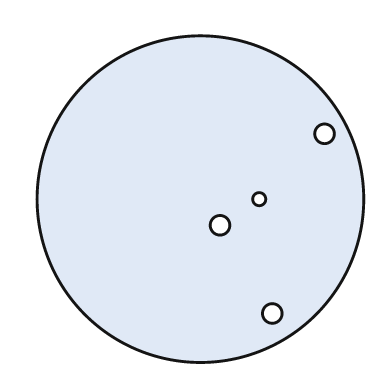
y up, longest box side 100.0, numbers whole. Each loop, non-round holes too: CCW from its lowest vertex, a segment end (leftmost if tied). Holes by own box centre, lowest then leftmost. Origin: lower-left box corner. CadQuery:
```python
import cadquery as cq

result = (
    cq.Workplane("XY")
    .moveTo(50.0, 50.0)
    .circle(50.0)
    .moveTo(72.0, 15.0)
    .circle(3.0)
    .moveTo(56.0, 42.0)
    .circle(3.0)
    .moveTo(68.0, 50.0)
    .circle(2.0)
    .moveTo(88.0, 70.0)
    .circle(3.0)
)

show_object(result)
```